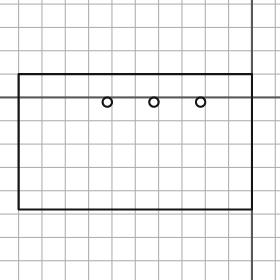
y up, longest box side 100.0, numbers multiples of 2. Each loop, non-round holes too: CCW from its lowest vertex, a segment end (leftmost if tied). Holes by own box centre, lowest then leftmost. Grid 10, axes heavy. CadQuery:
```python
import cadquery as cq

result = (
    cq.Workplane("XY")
    .moveTo(-100.0, -48.0)
    .lineTo(0.0, -48.0)
    .lineTo(0.0, 10.0)
    .lineTo(-100.0, 10.0)
    .close()
    .moveTo(-62.0, -2.0)
    .circle(2.0)
    .moveTo(-42.0, -2.0)
    .circle(2.0)
    .moveTo(-22.0, -2.0)
    .circle(2.0)
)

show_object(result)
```